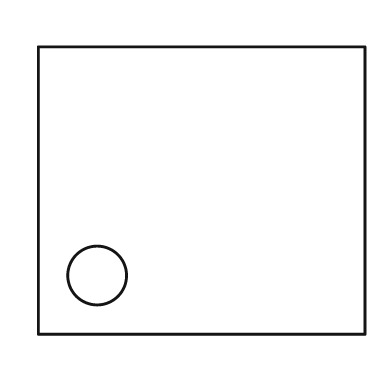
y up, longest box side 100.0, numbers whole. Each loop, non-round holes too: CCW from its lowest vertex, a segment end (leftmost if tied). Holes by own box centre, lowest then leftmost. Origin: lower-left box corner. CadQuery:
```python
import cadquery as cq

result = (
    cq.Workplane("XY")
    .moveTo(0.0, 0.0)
    .lineTo(100.0, 0.0)
    .lineTo(100.0, 88.0)
    .lineTo(0.0, 88.0)
    .close()
    .moveTo(18.0, 18.0)
    .circle(9.0)
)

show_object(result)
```